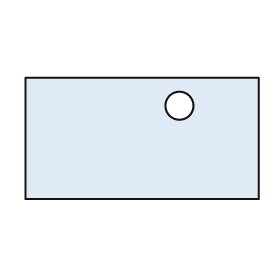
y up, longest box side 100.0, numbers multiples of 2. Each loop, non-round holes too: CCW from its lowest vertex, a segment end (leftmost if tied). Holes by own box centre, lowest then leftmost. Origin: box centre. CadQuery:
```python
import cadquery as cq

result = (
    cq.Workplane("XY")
    .moveTo(-50.0, -26.0)
    .lineTo(50.0, -26.0)
    .lineTo(50.0, 26.0)
    .lineTo(-50.0, 26.0)
    .close()
    .moveTo(16.0, 14.0)
    .circle(6.0)
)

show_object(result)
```